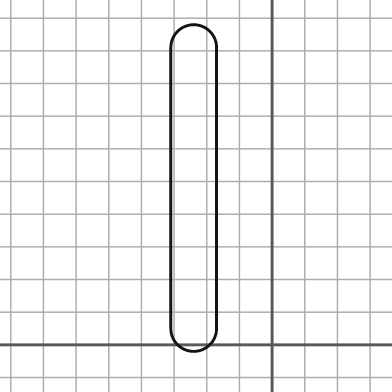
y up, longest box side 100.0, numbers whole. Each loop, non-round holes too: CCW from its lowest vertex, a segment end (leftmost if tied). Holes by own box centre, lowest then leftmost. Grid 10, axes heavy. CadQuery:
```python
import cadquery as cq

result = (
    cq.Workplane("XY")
    .moveTo(-31.0, 5.0)
    .threePointArc((-24.0, -2.0), (-17.0, 5.0))
    .lineTo(-17.0, 91.0)
    .threePointArc((-24.0, 98.0), (-31.0, 91.0))
    .close()
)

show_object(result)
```